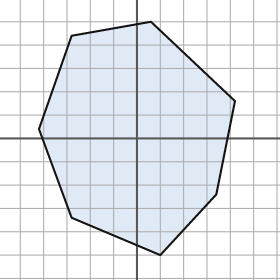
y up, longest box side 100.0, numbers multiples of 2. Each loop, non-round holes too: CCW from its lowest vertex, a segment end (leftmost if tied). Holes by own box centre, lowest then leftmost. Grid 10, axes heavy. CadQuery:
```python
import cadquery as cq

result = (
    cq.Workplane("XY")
    .moveTo(10.0, -50.0)
    .lineTo(34.0, -24.0)
    .lineTo(42.0, 16.0)
    .lineTo(6.0, 50.0)
    .lineTo(-28.0, 44.0)
    .lineTo(-42.0, 4.0)
    .lineTo(-28.0, -34.0)
    .close()
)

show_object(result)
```